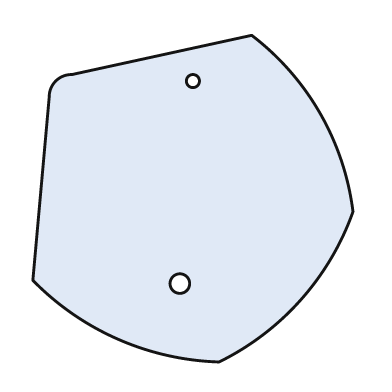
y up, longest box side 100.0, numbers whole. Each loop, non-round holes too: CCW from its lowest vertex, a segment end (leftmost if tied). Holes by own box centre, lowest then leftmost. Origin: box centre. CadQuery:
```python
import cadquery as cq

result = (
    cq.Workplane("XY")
    .moveTo(8.0, -50.0)
    .threePointArc((33.0, -31.0), (49.0, -4.0))
    .threePointArc((39.0, 26.0), (18.0, 50.0))
    .lineTo(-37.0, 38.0)
    .threePointArc((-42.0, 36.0), (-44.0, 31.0))
    .lineTo(-49.0, -25.0)
    .threePointArc((-23.0, -43.0), (8.0, -50.0))
    .close()
    .moveTo(-4.0, -26.0)
    .circle(3.0)
    .moveTo(0.0, 36.0)
    .circle(2.0)
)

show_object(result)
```